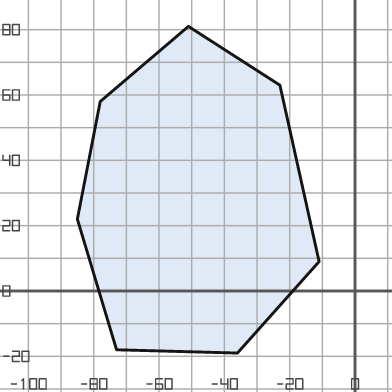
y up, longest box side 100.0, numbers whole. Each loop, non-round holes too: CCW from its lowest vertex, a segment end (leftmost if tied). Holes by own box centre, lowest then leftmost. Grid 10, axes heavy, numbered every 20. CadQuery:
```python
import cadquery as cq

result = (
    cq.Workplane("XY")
    .moveTo(-36.0, -19.0)
    .lineTo(-11.0, 9.0)
    .lineTo(-23.0, 63.0)
    .lineTo(-51.0, 81.0)
    .lineTo(-78.0, 58.0)
    .lineTo(-85.0, 22.0)
    .lineTo(-73.0, -18.0)
    .close()
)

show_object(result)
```